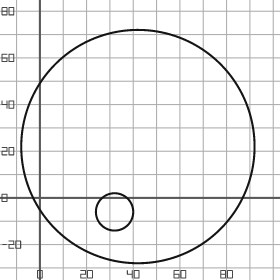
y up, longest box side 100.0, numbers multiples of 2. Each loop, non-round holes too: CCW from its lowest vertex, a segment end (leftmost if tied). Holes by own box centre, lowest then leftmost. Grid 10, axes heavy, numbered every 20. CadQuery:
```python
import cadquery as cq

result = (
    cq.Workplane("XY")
    .moveTo(42.0, 22.0)
    .circle(50.0)
    .moveTo(32.0, -6.0)
    .circle(8.0)
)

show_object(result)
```